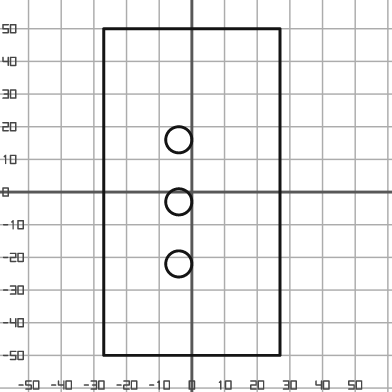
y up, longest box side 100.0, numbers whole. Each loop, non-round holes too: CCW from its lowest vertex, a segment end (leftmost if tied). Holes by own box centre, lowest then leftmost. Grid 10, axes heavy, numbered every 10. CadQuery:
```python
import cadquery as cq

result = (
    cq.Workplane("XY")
    .moveTo(-27.0, -50.0)
    .lineTo(27.0, -50.0)
    .lineTo(27.0, 50.0)
    .lineTo(-27.0, 50.0)
    .close()
    .moveTo(-4.0, -22.0)
    .circle(4.0)
    .moveTo(-4.0, -3.0)
    .circle(4.0)
    .moveTo(-4.0, 16.0)
    .circle(4.0)
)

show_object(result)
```